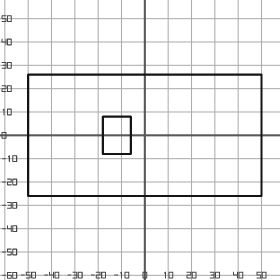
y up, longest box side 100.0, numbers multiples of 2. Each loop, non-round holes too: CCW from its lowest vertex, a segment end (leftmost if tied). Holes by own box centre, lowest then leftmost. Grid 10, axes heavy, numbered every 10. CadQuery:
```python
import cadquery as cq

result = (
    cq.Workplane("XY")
    .moveTo(-50.0, -26.0)
    .lineTo(50.0, -26.0)
    .lineTo(50.0, 26.0)
    .lineTo(-50.0, 26.0)
    .close()
    .moveTo(-18.0, -8.0)
    .lineTo(-6.0, -8.0)
    .lineTo(-6.0, 8.0)
    .lineTo(-18.0, 8.0)
    .close()
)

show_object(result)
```